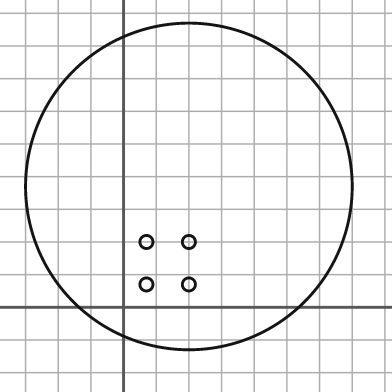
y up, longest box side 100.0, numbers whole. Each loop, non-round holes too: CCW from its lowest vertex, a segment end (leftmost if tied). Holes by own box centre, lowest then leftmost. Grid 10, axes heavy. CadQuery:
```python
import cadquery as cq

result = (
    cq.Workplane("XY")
    .moveTo(20.0, 37.0)
    .circle(50.0)
    .moveTo(7.0, 7.0)
    .circle(2.0)
    .moveTo(20.0, 7.0)
    .circle(2.0)
    .moveTo(7.0, 20.0)
    .circle(2.0)
    .moveTo(20.0, 20.0)
    .circle(2.0)
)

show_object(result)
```